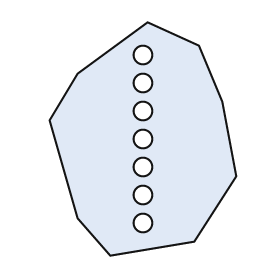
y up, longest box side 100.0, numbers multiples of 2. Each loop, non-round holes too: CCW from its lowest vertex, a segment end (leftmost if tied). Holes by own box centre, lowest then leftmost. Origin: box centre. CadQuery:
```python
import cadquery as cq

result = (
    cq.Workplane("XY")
    .moveTo(-14.0, -50.0)
    .lineTo(22.0, -44.0)
    .lineTo(40.0, -16.0)
    .lineTo(34.0, 16.0)
    .lineTo(24.0, 40.0)
    .lineTo(2.0, 50.0)
    .lineTo(-28.0, 28.0)
    .lineTo(-40.0, 8.0)
    .lineTo(-28.0, -34.0)
    .close()
    .moveTo(0.0, -36.0)
    .circle(4.0)
    .moveTo(0.0, -24.0)
    .circle(4.0)
    .moveTo(0.0, -12.0)
    .circle(4.0)
    .moveTo(0.0, 0.0)
    .circle(4.0)
    .moveTo(0.0, 12.0)
    .circle(4.0)
    .moveTo(0.0, 24.0)
    .circle(4.0)
    .moveTo(0.0, 36.0)
    .circle(4.0)
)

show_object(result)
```